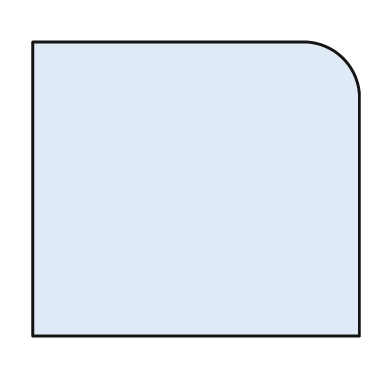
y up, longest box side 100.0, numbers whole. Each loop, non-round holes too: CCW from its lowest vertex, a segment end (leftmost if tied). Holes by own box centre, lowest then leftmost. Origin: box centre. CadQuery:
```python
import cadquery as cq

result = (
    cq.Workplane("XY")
    .moveTo(-50.0, -45.0)
    .lineTo(50.0, -45.0)
    .lineTo(50.0, 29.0)
    .threePointArc((45.0, 40.0), (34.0, 45.0))
    .lineTo(-50.0, 45.0)
    .close()
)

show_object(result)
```